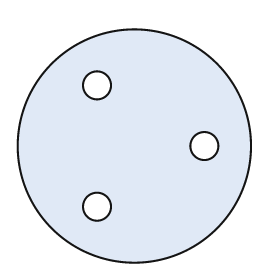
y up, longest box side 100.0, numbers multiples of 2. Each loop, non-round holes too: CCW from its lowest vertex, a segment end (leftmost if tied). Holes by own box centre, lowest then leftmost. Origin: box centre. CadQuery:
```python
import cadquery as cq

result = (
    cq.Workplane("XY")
    .moveTo(0.0, 0.0)
    .circle(50.0)
    .moveTo(-16.0, -26.0)
    .circle(6.0)
    .moveTo(30.0, 0.0)
    .circle(6.0)
    .moveTo(-16.0, 26.0)
    .circle(6.0)
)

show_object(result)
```